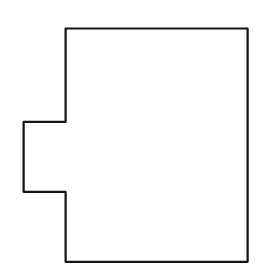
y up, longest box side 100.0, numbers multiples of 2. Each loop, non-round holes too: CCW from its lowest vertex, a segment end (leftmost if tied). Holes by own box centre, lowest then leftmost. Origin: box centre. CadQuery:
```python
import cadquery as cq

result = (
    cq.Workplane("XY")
    .moveTo(-30.0, -50.0)
    .lineTo(48.0, -50.0)
    .lineTo(48.0, 50.0)
    .lineTo(-30.0, 50.0)
    .lineTo(-30.0, 10.0)
    .lineTo(-48.0, 10.0)
    .lineTo(-48.0, -20.0)
    .lineTo(-30.0, -20.0)
    .close()
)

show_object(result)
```